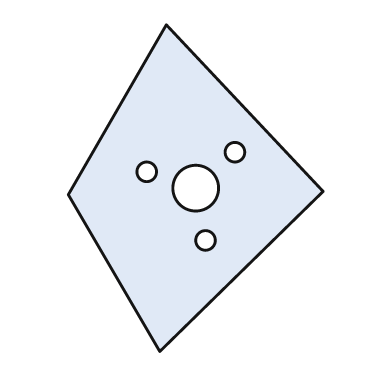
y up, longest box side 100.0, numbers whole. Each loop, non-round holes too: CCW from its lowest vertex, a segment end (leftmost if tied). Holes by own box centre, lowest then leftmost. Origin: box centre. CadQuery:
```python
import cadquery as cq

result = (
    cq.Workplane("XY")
    .moveTo(-11.0, -50.0)
    .lineTo(39.0, -1.0)
    .lineTo(-9.0, 50.0)
    .lineTo(-39.0, -2.0)
    .close()
    .moveTo(3.0, -16.0)
    .circle(3.0)
    .moveTo(0.0, 0.0)
    .circle(7.0)
    .moveTo(-15.0, 5.0)
    .circle(3.0)
    .moveTo(12.0, 11.0)
    .circle(3.0)
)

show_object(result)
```